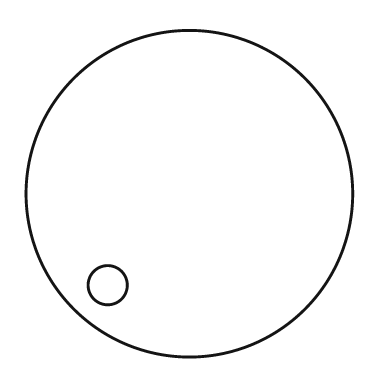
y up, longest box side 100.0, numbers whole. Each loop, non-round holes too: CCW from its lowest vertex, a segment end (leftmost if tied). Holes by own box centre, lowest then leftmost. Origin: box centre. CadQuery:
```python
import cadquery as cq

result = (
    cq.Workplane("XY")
    .moveTo(0.0, 0.0)
    .circle(50.0)
    .moveTo(-25.0, -28.0)
    .circle(6.0)
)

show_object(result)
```